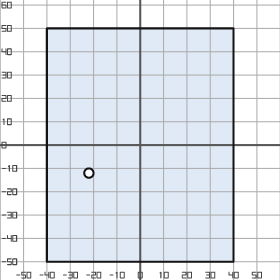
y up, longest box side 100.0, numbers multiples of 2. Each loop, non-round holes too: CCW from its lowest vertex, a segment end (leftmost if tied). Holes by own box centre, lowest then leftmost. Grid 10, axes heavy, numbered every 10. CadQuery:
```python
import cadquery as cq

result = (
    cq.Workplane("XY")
    .moveTo(-40.0, -50.0)
    .lineTo(40.0, -50.0)
    .lineTo(40.0, 50.0)
    .lineTo(-40.0, 50.0)
    .close()
    .moveTo(-22.0, -12.0)
    .circle(2.0)
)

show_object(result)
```